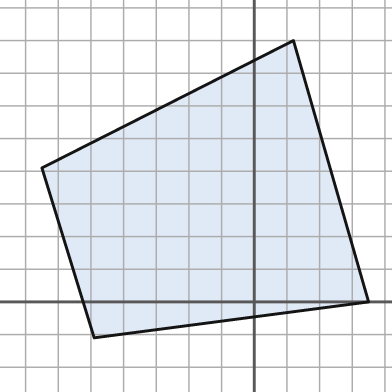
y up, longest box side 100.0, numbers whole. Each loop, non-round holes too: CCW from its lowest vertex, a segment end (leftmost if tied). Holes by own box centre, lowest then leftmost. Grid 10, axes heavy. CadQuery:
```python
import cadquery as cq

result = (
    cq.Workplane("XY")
    .moveTo(-49.0, -11.0)
    .lineTo(35.0, 0.0)
    .lineTo(12.0, 80.0)
    .lineTo(-65.0, 41.0)
    .close()
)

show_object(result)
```